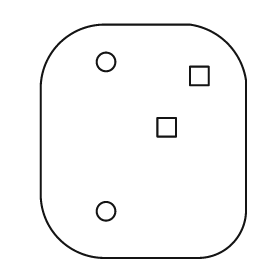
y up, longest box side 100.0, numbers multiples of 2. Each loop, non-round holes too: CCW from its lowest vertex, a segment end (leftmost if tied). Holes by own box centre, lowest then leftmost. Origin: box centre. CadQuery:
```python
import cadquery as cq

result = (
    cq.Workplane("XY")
    .moveTo(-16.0, -50.0)
    .lineTo(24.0, -50.0)
    .threePointArc((38.0, -44.0), (44.0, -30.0))
    .lineTo(44.0, 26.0)
    .threePointArc((36.0, 42.0), (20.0, 50.0))
    .lineTo(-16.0, 50.0)
    .threePointArc((-36.0, 42.0), (-44.0, 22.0))
    .lineTo(-44.0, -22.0)
    .threePointArc((-36.0, -42.0), (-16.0, -50.0))
    .close()
    .moveTo(-16.0, -30.0)
    .circle(4.0)
    .moveTo(6.0, 2.0)
    .lineTo(14.0, 2.0)
    .lineTo(14.0, 10.0)
    .lineTo(6.0, 10.0)
    .close()
    .moveTo(20.0, 24.0)
    .lineTo(28.0, 24.0)
    .lineTo(28.0, 32.0)
    .lineTo(20.0, 32.0)
    .close()
    .moveTo(-16.0, 34.0)
    .circle(4.0)
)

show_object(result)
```